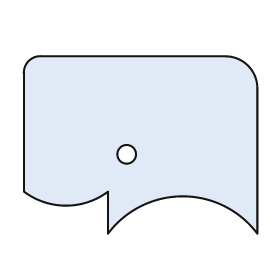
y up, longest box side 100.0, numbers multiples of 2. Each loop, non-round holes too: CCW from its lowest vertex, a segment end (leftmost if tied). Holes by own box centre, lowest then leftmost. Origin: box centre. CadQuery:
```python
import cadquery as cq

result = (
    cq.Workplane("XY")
    .moveTo(-14.0, -38.0)
    .threePointArc((18.0, -22.0), (50.0, -38.0))
    .lineTo(50.0, 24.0)
    .threePointArc((46.0, 34.0), (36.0, 38.0))
    .lineTo(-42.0, 38.0)
    .threePointArc((-48.0, 36.0), (-50.0, 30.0))
    .lineTo(-50.0, -20.0)
    .threePointArc((-32.0, -26.0), (-14.0, -20.0))
    .close()
    .moveTo(-6.0, -4.0)
    .circle(4.0)
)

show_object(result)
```